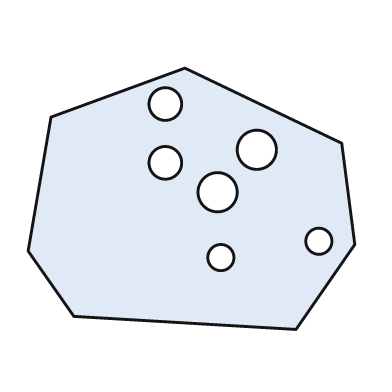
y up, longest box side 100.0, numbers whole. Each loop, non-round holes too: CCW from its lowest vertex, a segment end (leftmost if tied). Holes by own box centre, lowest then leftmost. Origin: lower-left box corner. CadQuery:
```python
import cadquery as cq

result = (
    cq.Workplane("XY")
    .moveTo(82.0, 0.0)
    .lineTo(100.0, 26.0)
    .lineTo(96.0, 57.0)
    .lineTo(48.0, 80.0)
    .lineTo(7.0, 65.0)
    .lineTo(0.0, 24.0)
    .lineTo(14.0, 4.0)
    .close()
    .moveTo(59.0, 22.0)
    .circle(4.0)
    .moveTo(89.0, 27.0)
    .circle(4.0)
    .moveTo(58.0, 42.0)
    .circle(6.0)
    .moveTo(42.0, 51.0)
    .circle(5.0)
    .moveTo(70.0, 55.0)
    .circle(6.0)
    .moveTo(42.0, 69.0)
    .circle(5.0)
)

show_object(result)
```